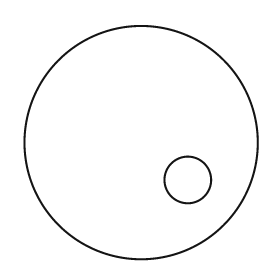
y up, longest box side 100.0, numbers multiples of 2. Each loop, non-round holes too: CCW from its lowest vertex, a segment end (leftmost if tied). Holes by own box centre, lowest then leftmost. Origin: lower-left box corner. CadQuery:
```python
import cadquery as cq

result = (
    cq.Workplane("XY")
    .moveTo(50.0, 50.0)
    .circle(50.0)
    .moveTo(70.0, 34.0)
    .circle(10.0)
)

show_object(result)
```